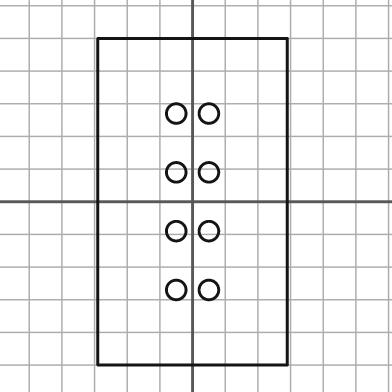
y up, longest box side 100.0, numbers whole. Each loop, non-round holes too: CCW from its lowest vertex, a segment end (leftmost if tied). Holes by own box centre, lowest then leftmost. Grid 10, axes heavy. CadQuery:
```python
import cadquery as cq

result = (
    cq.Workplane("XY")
    .moveTo(-29.0, -50.0)
    .lineTo(29.0, -50.0)
    .lineTo(29.0, 50.0)
    .lineTo(-29.0, 50.0)
    .close()
    .moveTo(-5.0, -27.0)
    .circle(3.0)
    .moveTo(5.0, -27.0)
    .circle(3.0)
    .moveTo(-5.0, -9.0)
    .circle(3.0)
    .moveTo(5.0, -9.0)
    .circle(3.0)
    .moveTo(-5.0, 9.0)
    .circle(3.0)
    .moveTo(5.0, 9.0)
    .circle(3.0)
    .moveTo(-5.0, 27.0)
    .circle(3.0)
    .moveTo(5.0, 27.0)
    .circle(3.0)
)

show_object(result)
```